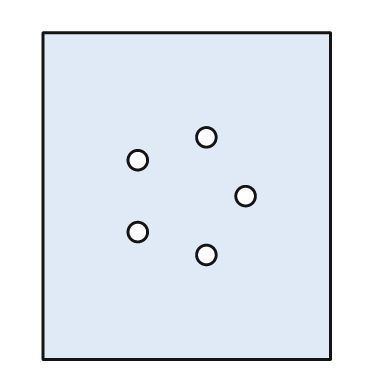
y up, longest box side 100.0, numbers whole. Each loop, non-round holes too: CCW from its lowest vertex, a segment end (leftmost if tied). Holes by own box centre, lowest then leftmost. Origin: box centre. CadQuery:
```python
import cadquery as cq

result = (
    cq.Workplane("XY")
    .moveTo(-44.0, -50.0)
    .lineTo(44.0, -50.0)
    .lineTo(44.0, 50.0)
    .lineTo(-44.0, 50.0)
    .close()
    .moveTo(6.0, -18.0)
    .circle(3.0)
    .moveTo(-15.0, -11.0)
    .circle(3.0)
    .moveTo(18.0, 0.0)
    .circle(3.0)
    .moveTo(-15.0, 11.0)
    .circle(3.0)
    .moveTo(6.0, 18.0)
    .circle(3.0)
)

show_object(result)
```